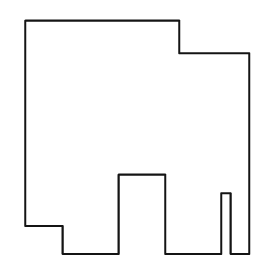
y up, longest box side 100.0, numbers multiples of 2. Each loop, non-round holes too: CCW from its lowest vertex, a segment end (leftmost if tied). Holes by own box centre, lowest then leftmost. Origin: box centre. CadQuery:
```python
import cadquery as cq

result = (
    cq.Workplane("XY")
    .moveTo(-32.0, -50.0)
    .lineTo(-8.0, -50.0)
    .lineTo(-8.0, -16.0)
    .lineTo(12.0, -16.0)
    .lineTo(12.0, -50.0)
    .lineTo(36.0, -50.0)
    .lineTo(36.0, -24.0)
    .lineTo(40.0, -24.0)
    .lineTo(40.0, -50.0)
    .lineTo(48.0, -50.0)
    .lineTo(48.0, 36.0)
    .lineTo(18.0, 36.0)
    .lineTo(18.0, 50.0)
    .lineTo(-48.0, 50.0)
    .lineTo(-48.0, -38.0)
    .lineTo(-32.0, -38.0)
    .close()
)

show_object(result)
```